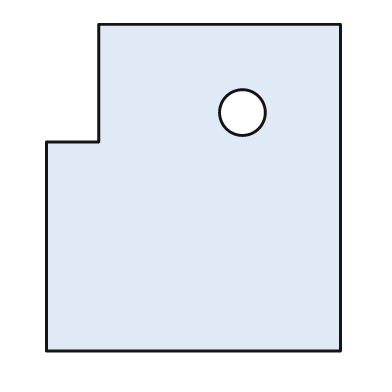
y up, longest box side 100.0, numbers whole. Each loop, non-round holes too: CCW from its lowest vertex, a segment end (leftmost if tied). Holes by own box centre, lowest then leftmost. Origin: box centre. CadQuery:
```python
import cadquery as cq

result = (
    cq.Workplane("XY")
    .moveTo(-45.0, -50.0)
    .lineTo(45.0, -50.0)
    .lineTo(45.0, 50.0)
    .lineTo(-29.0, 50.0)
    .lineTo(-29.0, 14.0)
    .lineTo(-45.0, 14.0)
    .close()
    .moveTo(15.0, 23.0)
    .circle(7.0)
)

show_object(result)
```